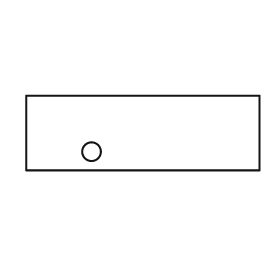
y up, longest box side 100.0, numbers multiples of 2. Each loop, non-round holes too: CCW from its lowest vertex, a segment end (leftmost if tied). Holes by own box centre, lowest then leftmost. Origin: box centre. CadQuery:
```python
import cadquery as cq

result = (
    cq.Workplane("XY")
    .moveTo(-50.0, -16.0)
    .lineTo(50.0, -16.0)
    .lineTo(50.0, 16.0)
    .lineTo(-50.0, 16.0)
    .close()
    .moveTo(-22.0, -8.0)
    .circle(4.0)
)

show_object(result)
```